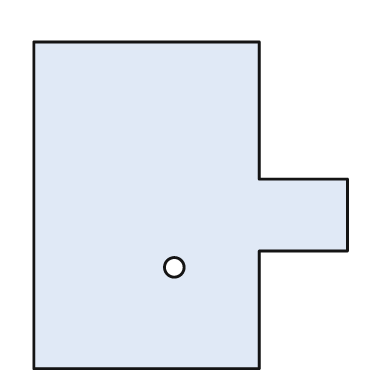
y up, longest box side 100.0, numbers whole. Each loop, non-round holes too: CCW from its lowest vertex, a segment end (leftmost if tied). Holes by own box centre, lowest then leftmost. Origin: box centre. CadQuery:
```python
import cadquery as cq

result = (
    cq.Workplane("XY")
    .moveTo(-48.0, -50.0)
    .lineTo(21.0, -50.0)
    .lineTo(21.0, -14.0)
    .lineTo(48.0, -14.0)
    .lineTo(48.0, 8.0)
    .lineTo(21.0, 8.0)
    .lineTo(21.0, 50.0)
    .lineTo(-48.0, 50.0)
    .close()
    .moveTo(-5.0, -19.0)
    .circle(3.0)
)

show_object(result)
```